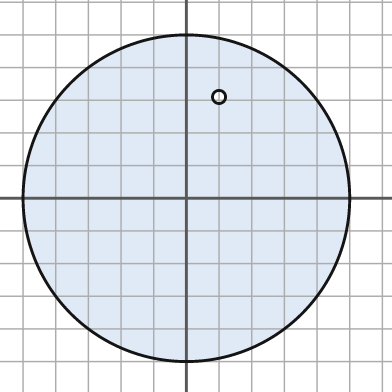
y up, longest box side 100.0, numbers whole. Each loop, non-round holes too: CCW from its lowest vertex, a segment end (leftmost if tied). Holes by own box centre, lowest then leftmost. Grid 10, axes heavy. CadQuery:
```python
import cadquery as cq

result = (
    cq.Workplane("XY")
    .moveTo(0.0, 0.0)
    .circle(50.0)
    .moveTo(10.0, 31.0)
    .circle(2.0)
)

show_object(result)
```